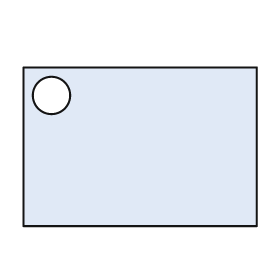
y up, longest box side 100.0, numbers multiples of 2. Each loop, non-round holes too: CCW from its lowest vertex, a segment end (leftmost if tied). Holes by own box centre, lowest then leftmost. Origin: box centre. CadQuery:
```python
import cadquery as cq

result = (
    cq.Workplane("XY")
    .moveTo(-50.0, -34.0)
    .lineTo(50.0, -34.0)
    .lineTo(50.0, 34.0)
    .lineTo(-50.0, 34.0)
    .close()
    .moveTo(-38.0, 22.0)
    .circle(8.0)
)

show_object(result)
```